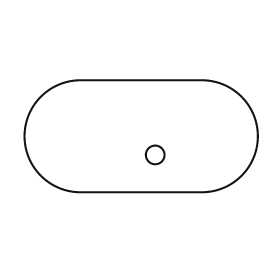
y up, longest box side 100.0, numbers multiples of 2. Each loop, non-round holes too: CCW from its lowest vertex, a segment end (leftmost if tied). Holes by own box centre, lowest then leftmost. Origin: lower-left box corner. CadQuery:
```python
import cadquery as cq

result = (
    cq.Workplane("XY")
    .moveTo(24.0, 0.0)
    .lineTo(76.0, 0.0)
    .threePointArc((100.0, 24.0), (76.0, 48.0))
    .lineTo(24.0, 48.0)
    .threePointArc((0.0, 24.0), (24.0, 0.0))
    .close()
    .moveTo(56.0, 16.0)
    .circle(4.0)
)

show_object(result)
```